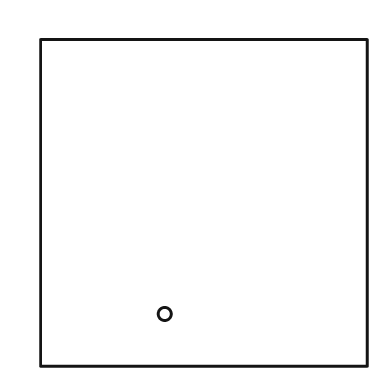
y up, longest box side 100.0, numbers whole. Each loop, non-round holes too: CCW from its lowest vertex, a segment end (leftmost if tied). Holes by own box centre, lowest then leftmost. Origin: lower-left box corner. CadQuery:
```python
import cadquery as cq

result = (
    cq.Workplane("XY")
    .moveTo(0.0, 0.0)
    .lineTo(100.0, 0.0)
    .lineTo(100.0, 100.0)
    .lineTo(0.0, 100.0)
    .close()
    .moveTo(38.0, 16.0)
    .circle(2.0)
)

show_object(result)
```